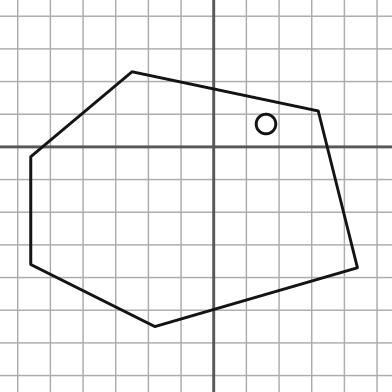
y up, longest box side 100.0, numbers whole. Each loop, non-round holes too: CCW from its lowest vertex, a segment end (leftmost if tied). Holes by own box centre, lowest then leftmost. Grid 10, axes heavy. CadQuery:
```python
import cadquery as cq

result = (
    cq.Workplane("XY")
    .moveTo(-18.0, -55.0)
    .lineTo(44.0, -37.0)
    .lineTo(32.0, 11.0)
    .lineTo(-25.0, 23.0)
    .lineTo(-56.0, -3.0)
    .lineTo(-56.0, -36.0)
    .close()
    .moveTo(16.0, 7.0)
    .circle(3.0)
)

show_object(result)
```